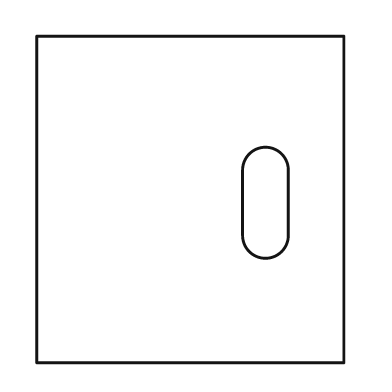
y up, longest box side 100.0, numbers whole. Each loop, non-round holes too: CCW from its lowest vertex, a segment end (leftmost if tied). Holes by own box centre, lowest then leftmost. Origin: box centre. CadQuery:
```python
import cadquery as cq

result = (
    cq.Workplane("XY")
    .moveTo(-47.0, -50.0)
    .lineTo(47.0, -50.0)
    .lineTo(47.0, 50.0)
    .lineTo(-47.0, 50.0)
    .close()
    .moveTo(16.0, -11.0)
    .threePointArc((23.0, -18.0), (30.0, -11.0))
    .lineTo(30.0, 9.0)
    .threePointArc((23.0, 16.0), (16.0, 9.0))
    .close()
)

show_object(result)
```